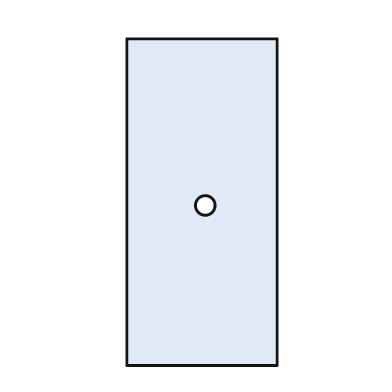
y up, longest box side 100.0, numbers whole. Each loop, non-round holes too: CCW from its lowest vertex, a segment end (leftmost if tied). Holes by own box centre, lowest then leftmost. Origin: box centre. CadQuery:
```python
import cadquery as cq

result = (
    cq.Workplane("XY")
    .moveTo(-23.0, -50.0)
    .lineTo(23.0, -50.0)
    .lineTo(23.0, 50.0)
    .lineTo(-23.0, 50.0)
    .close()
    .moveTo(1.0, -1.0)
    .circle(3.0)
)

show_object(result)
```